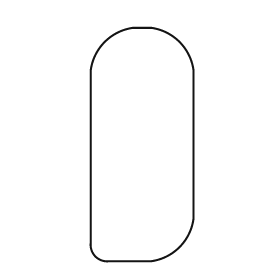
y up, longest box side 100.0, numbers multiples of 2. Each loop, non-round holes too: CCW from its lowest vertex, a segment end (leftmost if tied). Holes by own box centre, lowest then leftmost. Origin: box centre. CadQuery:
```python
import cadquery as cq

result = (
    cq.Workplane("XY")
    .moveTo(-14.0, -50.0)
    .lineTo(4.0, -50.0)
    .threePointArc((16.0, -44.0), (22.0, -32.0))
    .lineTo(22.0, 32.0)
    .threePointArc((16.0, 44.0), (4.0, 50.0))
    .lineTo(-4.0, 50.0)
    .threePointArc((-16.0, 44.0), (-22.0, 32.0))
    .lineTo(-22.0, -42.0)
    .threePointArc((-20.0, -48.0), (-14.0, -50.0))
    .close()
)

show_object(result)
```